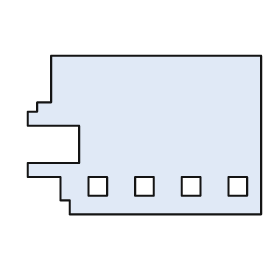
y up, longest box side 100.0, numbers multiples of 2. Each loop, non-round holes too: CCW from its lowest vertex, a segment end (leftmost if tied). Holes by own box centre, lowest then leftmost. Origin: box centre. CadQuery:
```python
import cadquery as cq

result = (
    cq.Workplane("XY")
    .moveTo(-32.0, -34.0)
    .lineTo(50.0, -34.0)
    .lineTo(50.0, 34.0)
    .lineTo(-40.0, 34.0)
    .lineTo(-40.0, 14.0)
    .lineTo(-46.0, 14.0)
    .lineTo(-46.0, 10.0)
    .lineTo(-50.0, 10.0)
    .lineTo(-50.0, 4.0)
    .lineTo(-28.0, 4.0)
    .lineTo(-28.0, -12.0)
    .lineTo(-50.0, -12.0)
    .lineTo(-50.0, -18.0)
    .lineTo(-36.0, -18.0)
    .lineTo(-36.0, -28.0)
    .lineTo(-32.0, -28.0)
    .close()
    .moveTo(-24.0, -26.0)
    .lineTo(-16.0, -26.0)
    .lineTo(-16.0, -18.0)
    .lineTo(-24.0, -18.0)
    .close()
    .moveTo(-4.0, -26.0)
    .lineTo(4.0, -26.0)
    .lineTo(4.0, -18.0)
    .lineTo(-4.0, -18.0)
    .close()
    .moveTo(16.0, -26.0)
    .lineTo(24.0, -26.0)
    .lineTo(24.0, -18.0)
    .lineTo(16.0, -18.0)
    .close()
    .moveTo(36.0, -26.0)
    .lineTo(44.0, -26.0)
    .lineTo(44.0, -18.0)
    .lineTo(36.0, -18.0)
    .close()
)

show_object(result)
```